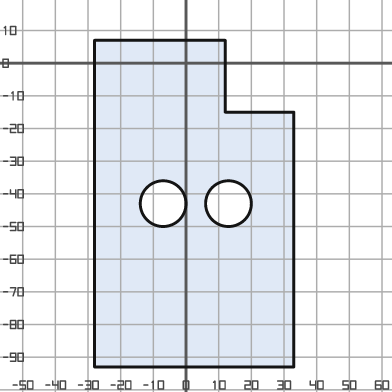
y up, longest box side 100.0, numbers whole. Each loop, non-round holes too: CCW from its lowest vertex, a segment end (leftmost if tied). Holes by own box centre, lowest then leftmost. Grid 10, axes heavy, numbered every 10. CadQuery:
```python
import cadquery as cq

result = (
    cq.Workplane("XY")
    .moveTo(-28.0, -93.0)
    .lineTo(33.0, -93.0)
    .lineTo(33.0, -15.0)
    .lineTo(12.0, -15.0)
    .lineTo(12.0, 7.0)
    .lineTo(-28.0, 7.0)
    .close()
    .moveTo(-7.0, -43.0)
    .circle(7.0)
    .moveTo(13.0, -43.0)
    .circle(7.0)
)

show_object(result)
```